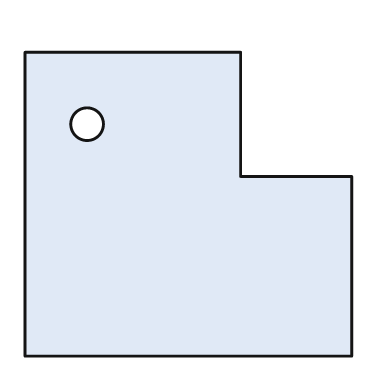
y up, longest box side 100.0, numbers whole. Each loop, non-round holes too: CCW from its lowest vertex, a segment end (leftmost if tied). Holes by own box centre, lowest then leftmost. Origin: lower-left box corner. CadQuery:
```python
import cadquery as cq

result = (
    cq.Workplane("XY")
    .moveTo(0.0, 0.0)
    .lineTo(100.0, 0.0)
    .lineTo(100.0, 55.0)
    .lineTo(66.0, 55.0)
    .lineTo(66.0, 93.0)
    .lineTo(0.0, 93.0)
    .close()
    .moveTo(19.0, 71.0)
    .circle(5.0)
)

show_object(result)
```